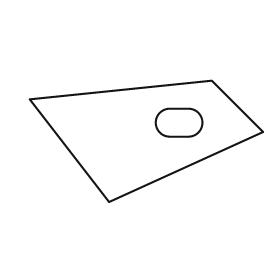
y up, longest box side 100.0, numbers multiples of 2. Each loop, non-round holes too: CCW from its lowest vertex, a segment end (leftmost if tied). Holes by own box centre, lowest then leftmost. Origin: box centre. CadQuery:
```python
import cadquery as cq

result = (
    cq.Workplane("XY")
    .moveTo(-16.0, -26.0)
    .lineTo(50.0, 4.0)
    .lineTo(28.0, 26.0)
    .lineTo(-50.0, 18.0)
    .close()
    .moveTo(10.0, 2.0)
    .lineTo(18.0, 2.0)
    .threePointArc((24.0, 8.0), (18.0, 14.0))
    .lineTo(10.0, 14.0)
    .threePointArc((4.0, 8.0), (10.0, 2.0))
    .close()
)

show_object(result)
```